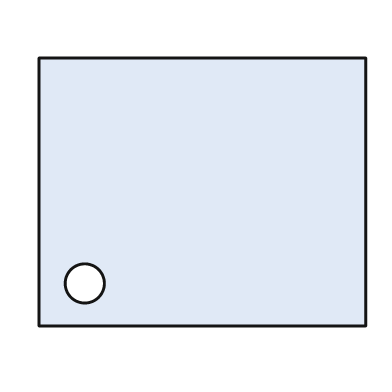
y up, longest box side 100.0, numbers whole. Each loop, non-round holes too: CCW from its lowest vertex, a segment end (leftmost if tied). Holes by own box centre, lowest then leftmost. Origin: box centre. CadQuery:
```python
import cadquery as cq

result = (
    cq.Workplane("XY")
    .moveTo(-50.0, -41.0)
    .lineTo(50.0, -41.0)
    .lineTo(50.0, 41.0)
    .lineTo(-50.0, 41.0)
    .close()
    .moveTo(-36.0, -28.0)
    .circle(6.0)
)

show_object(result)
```